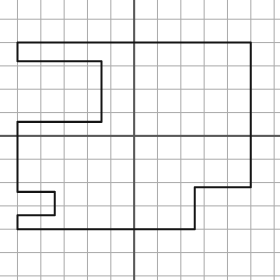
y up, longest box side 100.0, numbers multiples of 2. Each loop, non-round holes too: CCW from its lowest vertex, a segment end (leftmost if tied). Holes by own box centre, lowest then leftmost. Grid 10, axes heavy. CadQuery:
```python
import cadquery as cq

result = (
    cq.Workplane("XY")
    .moveTo(-50.0, -40.0)
    .lineTo(26.0, -40.0)
    .lineTo(26.0, -22.0)
    .lineTo(50.0, -22.0)
    .lineTo(50.0, 40.0)
    .lineTo(-50.0, 40.0)
    .lineTo(-50.0, 32.0)
    .lineTo(-14.0, 32.0)
    .lineTo(-14.0, 6.0)
    .lineTo(-50.0, 6.0)
    .lineTo(-50.0, -24.0)
    .lineTo(-34.0, -24.0)
    .lineTo(-34.0, -34.0)
    .lineTo(-50.0, -34.0)
    .close()
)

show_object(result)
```